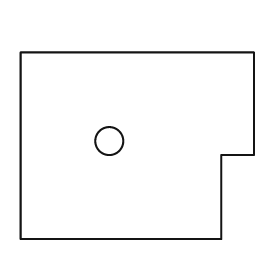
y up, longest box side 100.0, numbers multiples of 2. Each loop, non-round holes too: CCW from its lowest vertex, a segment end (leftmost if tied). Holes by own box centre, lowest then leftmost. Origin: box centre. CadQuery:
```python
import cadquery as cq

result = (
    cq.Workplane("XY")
    .moveTo(-50.0, -40.0)
    .lineTo(36.0, -40.0)
    .lineTo(36.0, -4.0)
    .lineTo(50.0, -4.0)
    .lineTo(50.0, 40.0)
    .lineTo(-50.0, 40.0)
    .close()
    .moveTo(-12.0, 2.0)
    .circle(6.0)
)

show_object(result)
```